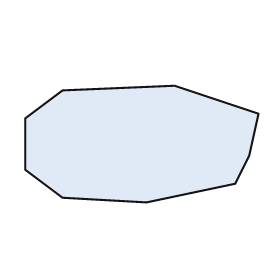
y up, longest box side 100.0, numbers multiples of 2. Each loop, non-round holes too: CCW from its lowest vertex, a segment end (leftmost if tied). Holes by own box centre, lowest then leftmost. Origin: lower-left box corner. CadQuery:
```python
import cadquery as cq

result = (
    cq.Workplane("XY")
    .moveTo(52.0, 0.0)
    .lineTo(90.0, 8.0)
    .lineTo(96.0, 20.0)
    .lineTo(100.0, 38.0)
    .lineTo(64.0, 50.0)
    .lineTo(16.0, 48.0)
    .lineTo(0.0, 36.0)
    .lineTo(0.0, 14.0)
    .lineTo(16.0, 2.0)
    .close()
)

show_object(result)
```